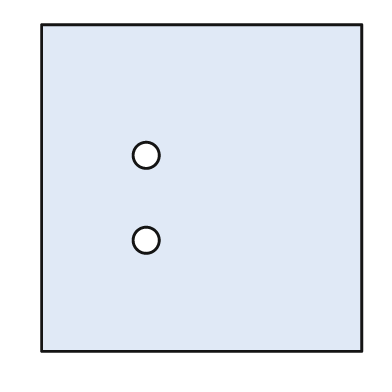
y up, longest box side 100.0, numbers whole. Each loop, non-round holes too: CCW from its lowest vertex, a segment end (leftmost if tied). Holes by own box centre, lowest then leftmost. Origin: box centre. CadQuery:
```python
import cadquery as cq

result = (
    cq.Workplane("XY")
    .moveTo(-49.0, -50.0)
    .lineTo(49.0, -50.0)
    .lineTo(49.0, 50.0)
    .lineTo(-49.0, 50.0)
    .close()
    .moveTo(-17.0, -16.0)
    .circle(4.0)
    .moveTo(-17.0, 10.0)
    .circle(4.0)
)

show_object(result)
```